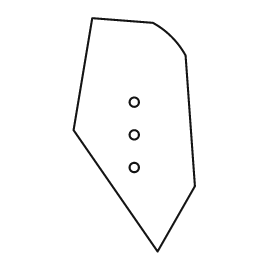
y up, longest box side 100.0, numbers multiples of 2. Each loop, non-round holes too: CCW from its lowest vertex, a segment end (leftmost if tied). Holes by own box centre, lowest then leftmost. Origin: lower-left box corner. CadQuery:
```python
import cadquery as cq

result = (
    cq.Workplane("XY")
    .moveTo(36.0, 0.0)
    .lineTo(52.0, 28.0)
    .lineTo(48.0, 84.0)
    .threePointArc((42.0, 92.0), (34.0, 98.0))
    .lineTo(8.0, 100.0)
    .lineTo(0.0, 52.0)
    .close()
    .moveTo(26.0, 36.0)
    .circle(2.0)
    .moveTo(26.0, 50.0)
    .circle(2.0)
    .moveTo(26.0, 64.0)
    .circle(2.0)
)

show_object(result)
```